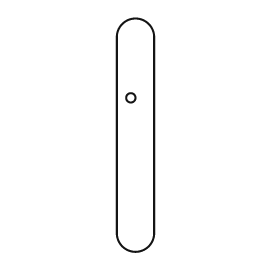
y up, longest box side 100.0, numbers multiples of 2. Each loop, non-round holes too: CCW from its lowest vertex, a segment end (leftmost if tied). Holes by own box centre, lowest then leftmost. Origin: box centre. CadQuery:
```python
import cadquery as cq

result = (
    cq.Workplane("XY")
    .moveTo(-8.0, -42.0)
    .threePointArc((0.0, -50.0), (8.0, -42.0))
    .lineTo(8.0, 42.0)
    .threePointArc((0.0, 50.0), (-8.0, 42.0))
    .close()
    .moveTo(-2.0, 16.0)
    .circle(2.0)
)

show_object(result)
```